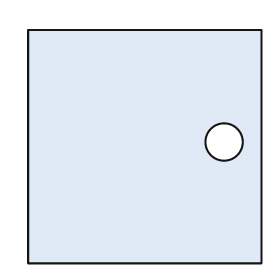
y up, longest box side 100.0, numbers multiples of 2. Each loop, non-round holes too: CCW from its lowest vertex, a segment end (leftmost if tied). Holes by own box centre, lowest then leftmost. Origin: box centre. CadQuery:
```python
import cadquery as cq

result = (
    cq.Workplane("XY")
    .moveTo(-50.0, -50.0)
    .lineTo(50.0, -50.0)
    .lineTo(50.0, 50.0)
    .lineTo(-50.0, 50.0)
    .close()
    .moveTo(34.0, 2.0)
    .circle(8.0)
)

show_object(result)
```